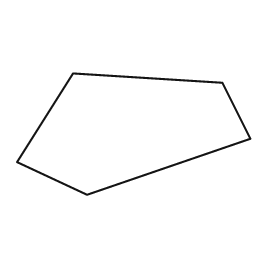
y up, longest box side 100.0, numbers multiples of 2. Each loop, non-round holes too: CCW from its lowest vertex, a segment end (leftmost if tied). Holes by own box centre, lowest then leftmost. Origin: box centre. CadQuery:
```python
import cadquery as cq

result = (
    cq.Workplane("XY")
    .moveTo(-20.0, -26.0)
    .lineTo(50.0, -2.0)
    .lineTo(38.0, 22.0)
    .lineTo(-26.0, 26.0)
    .lineTo(-50.0, -12.0)
    .close()
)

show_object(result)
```